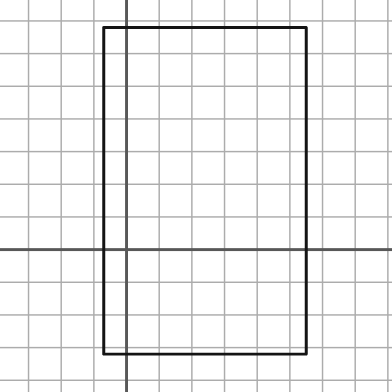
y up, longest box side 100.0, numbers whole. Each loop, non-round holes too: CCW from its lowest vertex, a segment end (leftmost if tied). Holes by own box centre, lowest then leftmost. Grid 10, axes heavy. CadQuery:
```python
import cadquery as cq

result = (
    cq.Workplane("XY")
    .moveTo(-7.0, -32.0)
    .lineTo(55.0, -32.0)
    .lineTo(55.0, 68.0)
    .lineTo(-7.0, 68.0)
    .close()
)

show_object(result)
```